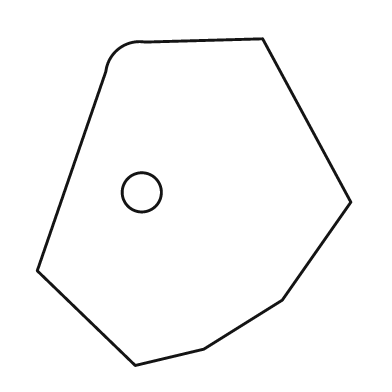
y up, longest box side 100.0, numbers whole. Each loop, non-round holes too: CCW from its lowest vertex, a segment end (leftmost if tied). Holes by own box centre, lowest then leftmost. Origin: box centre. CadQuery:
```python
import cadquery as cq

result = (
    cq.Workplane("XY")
    .moveTo(-18.0, -50.0)
    .lineTo(3.0, -45.0)
    .lineTo(27.0, -30.0)
    .lineTo(48.0, 0.0)
    .lineTo(21.0, 50.0)
    .lineTo(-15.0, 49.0)
    .threePointArc((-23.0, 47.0), (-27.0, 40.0))
    .lineTo(-48.0, -21.0)
    .close()
    .moveTo(-16.0, 3.0)
    .circle(6.0)
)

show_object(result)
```